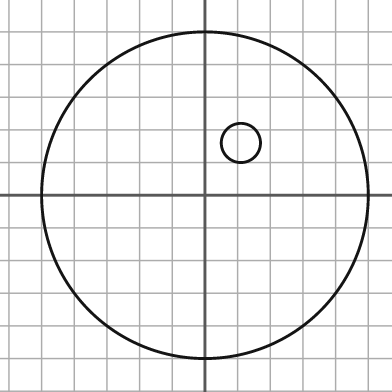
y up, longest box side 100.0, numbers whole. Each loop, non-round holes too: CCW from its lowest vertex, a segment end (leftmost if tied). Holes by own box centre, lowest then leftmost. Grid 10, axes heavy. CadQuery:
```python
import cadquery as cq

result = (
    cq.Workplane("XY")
    .moveTo(0.0, 0.0)
    .circle(50.0)
    .moveTo(11.0, 16.0)
    .circle(6.0)
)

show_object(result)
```